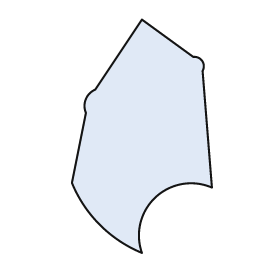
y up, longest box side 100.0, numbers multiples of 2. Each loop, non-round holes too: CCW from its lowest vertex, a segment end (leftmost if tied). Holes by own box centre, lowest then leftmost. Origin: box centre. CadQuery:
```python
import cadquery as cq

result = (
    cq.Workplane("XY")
    .moveTo(0.0, -50.0)
    .threePointArc((6.0, -26.0), (30.0, -22.0))
    .lineTo(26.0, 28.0)
    .threePointArc((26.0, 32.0), (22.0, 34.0))
    .lineTo(0.0, 50.0)
    .lineTo(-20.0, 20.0)
    .threePointArc((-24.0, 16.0), (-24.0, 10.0))
    .lineTo(-30.0, -20.0)
    .threePointArc((-18.0, -38.0), (0.0, -50.0))
    .close()
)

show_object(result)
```